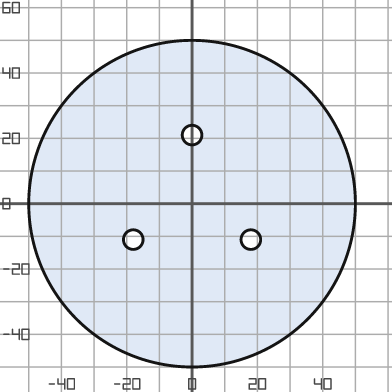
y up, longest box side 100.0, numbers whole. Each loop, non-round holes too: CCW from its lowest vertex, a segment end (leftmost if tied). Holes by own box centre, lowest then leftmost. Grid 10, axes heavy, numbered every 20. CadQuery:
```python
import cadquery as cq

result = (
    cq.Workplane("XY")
    .moveTo(0.0, 0.0)
    .circle(50.0)
    .moveTo(-18.0, -11.0)
    .circle(3.0)
    .moveTo(18.0, -11.0)
    .circle(3.0)
    .moveTo(0.0, 21.0)
    .circle(3.0)
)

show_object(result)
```